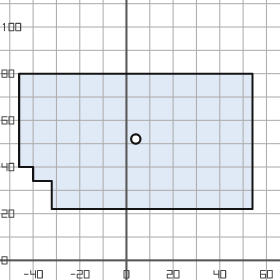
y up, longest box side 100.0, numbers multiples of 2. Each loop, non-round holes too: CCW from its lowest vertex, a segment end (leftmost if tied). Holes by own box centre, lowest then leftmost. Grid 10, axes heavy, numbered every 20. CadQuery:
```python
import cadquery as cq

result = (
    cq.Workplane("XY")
    .moveTo(-32.0, 22.0)
    .lineTo(54.0, 22.0)
    .lineTo(54.0, 80.0)
    .lineTo(-46.0, 80.0)
    .lineTo(-46.0, 40.0)
    .lineTo(-40.0, 40.0)
    .lineTo(-40.0, 34.0)
    .lineTo(-32.0, 34.0)
    .close()
    .moveTo(4.0, 52.0)
    .circle(2.0)
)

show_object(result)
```